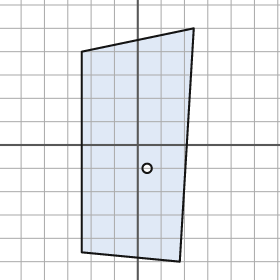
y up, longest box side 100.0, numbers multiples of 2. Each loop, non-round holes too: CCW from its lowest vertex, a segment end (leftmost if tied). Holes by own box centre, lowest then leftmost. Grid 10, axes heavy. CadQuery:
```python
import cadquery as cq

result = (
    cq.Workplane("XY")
    .moveTo(18.0, -50.0)
    .lineTo(24.0, 50.0)
    .lineTo(-24.0, 40.0)
    .lineTo(-24.0, -46.0)
    .close()
    .moveTo(4.0, -10.0)
    .circle(2.0)
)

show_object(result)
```